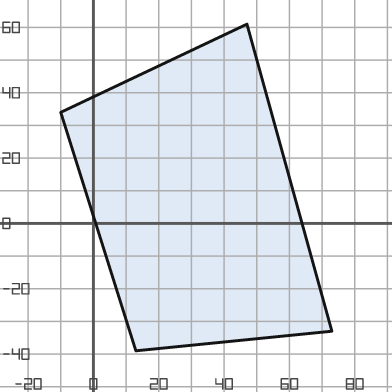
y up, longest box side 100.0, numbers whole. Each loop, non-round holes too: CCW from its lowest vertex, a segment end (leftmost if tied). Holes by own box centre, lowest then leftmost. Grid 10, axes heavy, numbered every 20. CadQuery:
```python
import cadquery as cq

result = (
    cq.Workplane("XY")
    .moveTo(13.0, -39.0)
    .lineTo(73.0, -33.0)
    .lineTo(47.0, 61.0)
    .lineTo(-10.0, 34.0)
    .close()
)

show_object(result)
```